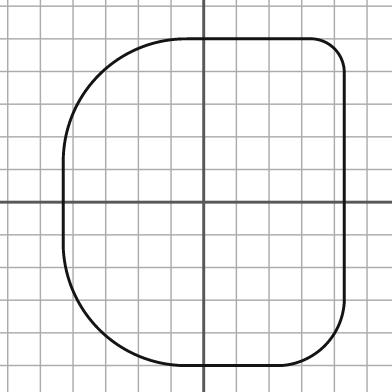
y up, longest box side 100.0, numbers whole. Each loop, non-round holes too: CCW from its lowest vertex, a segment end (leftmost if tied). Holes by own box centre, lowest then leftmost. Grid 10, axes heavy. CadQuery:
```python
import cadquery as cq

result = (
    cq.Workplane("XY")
    .moveTo(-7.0, -50.0)
    .lineTo(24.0, -50.0)
    .threePointArc((37.0, -44.0), (43.0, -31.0))
    .lineTo(43.0, 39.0)
    .threePointArc((40.0, 47.0), (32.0, 50.0))
    .lineTo(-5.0, 50.0)
    .threePointArc((-32.0, 39.0), (-43.0, 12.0))
    .lineTo(-43.0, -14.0)
    .threePointArc((-32.0, -39.0), (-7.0, -50.0))
    .close()
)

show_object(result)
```